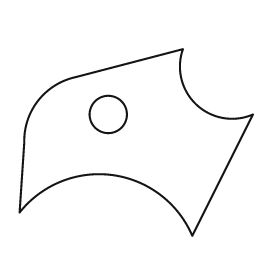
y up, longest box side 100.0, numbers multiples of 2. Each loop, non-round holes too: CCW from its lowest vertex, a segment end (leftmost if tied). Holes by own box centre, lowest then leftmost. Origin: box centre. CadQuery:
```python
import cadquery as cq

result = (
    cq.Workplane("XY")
    .moveTo(24.0, -40.0)
    .lineTo(50.0, 12.0)
    .threePointArc((26.0, 16.0), (20.0, 40.0))
    .lineTo(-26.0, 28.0)
    .threePointArc((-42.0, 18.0), (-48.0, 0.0))
    .lineTo(-50.0, -30.0)
    .threePointArc((-10.0, -14.0), (24.0, -40.0))
    .close()
    .moveTo(-12.0, 12.0)
    .circle(8.0)
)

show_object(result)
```